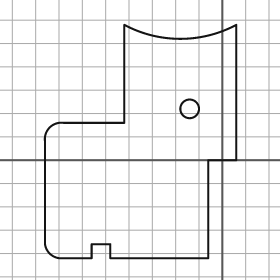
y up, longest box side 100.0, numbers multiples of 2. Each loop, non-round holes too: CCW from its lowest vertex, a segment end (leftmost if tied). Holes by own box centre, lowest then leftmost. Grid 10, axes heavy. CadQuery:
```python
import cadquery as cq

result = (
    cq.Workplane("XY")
    .moveTo(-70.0, -42.0)
    .lineTo(-56.0, -42.0)
    .lineTo(-56.0, -36.0)
    .lineTo(-48.0, -36.0)
    .lineTo(-48.0, -42.0)
    .lineTo(-6.0, -42.0)
    .lineTo(-6.0, 0.0)
    .lineTo(6.0, 0.0)
    .lineTo(6.0, 58.0)
    .threePointArc((-18.0, 52.0), (-42.0, 58.0))
    .lineTo(-42.0, 16.0)
    .lineTo(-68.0, 16.0)
    .threePointArc((-74.0, 14.0), (-76.0, 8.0))
    .lineTo(-76.0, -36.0)
    .threePointArc((-74.0, -40.0), (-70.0, -42.0))
    .close()
    .moveTo(-14.0, 22.0)
    .circle(4.0)
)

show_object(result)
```